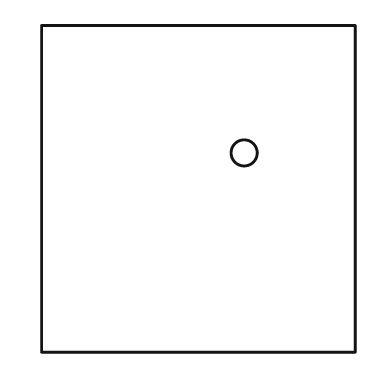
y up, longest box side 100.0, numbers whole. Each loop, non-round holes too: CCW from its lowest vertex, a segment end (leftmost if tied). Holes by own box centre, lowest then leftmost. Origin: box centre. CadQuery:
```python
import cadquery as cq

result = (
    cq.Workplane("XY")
    .moveTo(-48.0, -50.0)
    .lineTo(48.0, -50.0)
    .lineTo(48.0, 50.0)
    .lineTo(-48.0, 50.0)
    .close()
    .moveTo(14.0, 11.0)
    .circle(4.0)
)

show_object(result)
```